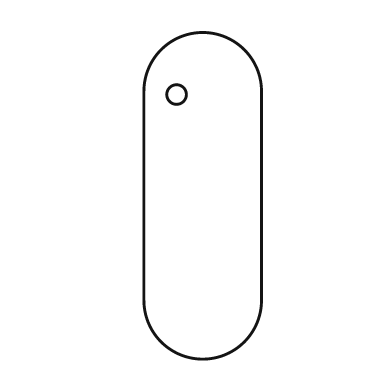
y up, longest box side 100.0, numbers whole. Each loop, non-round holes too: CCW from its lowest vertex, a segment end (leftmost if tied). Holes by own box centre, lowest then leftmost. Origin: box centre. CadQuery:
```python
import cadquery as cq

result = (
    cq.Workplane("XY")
    .moveTo(-18.0, -32.0)
    .threePointArc((0.0, -50.0), (18.0, -32.0))
    .lineTo(18.0, 32.0)
    .threePointArc((0.0, 50.0), (-18.0, 32.0))
    .close()
    .moveTo(-8.0, 31.0)
    .circle(3.0)
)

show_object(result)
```